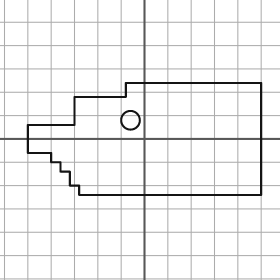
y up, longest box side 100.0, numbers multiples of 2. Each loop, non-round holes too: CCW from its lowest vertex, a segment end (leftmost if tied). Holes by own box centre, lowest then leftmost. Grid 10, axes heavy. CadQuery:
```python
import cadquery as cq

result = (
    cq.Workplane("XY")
    .moveTo(-28.0, -24.0)
    .lineTo(50.0, -24.0)
    .lineTo(50.0, 24.0)
    .lineTo(-8.0, 24.0)
    .lineTo(-8.0, 18.0)
    .lineTo(-30.0, 18.0)
    .lineTo(-30.0, 6.0)
    .lineTo(-50.0, 6.0)
    .lineTo(-50.0, -6.0)
    .lineTo(-40.0, -6.0)
    .lineTo(-40.0, -10.0)
    .lineTo(-36.0, -10.0)
    .lineTo(-36.0, -14.0)
    .lineTo(-32.0, -14.0)
    .lineTo(-32.0, -20.0)
    .lineTo(-28.0, -20.0)
    .close()
    .moveTo(-6.0, 8.0)
    .circle(4.0)
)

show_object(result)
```